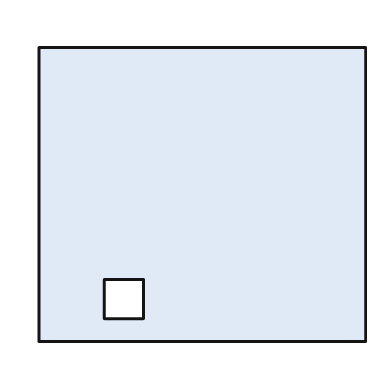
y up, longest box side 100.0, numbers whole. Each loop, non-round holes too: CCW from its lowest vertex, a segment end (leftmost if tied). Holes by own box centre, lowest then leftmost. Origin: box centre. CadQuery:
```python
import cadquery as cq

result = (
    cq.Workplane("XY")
    .moveTo(-50.0, -45.0)
    .lineTo(50.0, -45.0)
    .lineTo(50.0, 45.0)
    .lineTo(-50.0, 45.0)
    .close()
    .moveTo(-30.0, -38.0)
    .lineTo(-18.0, -38.0)
    .lineTo(-18.0, -26.0)
    .lineTo(-30.0, -26.0)
    .close()
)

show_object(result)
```